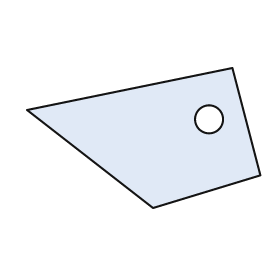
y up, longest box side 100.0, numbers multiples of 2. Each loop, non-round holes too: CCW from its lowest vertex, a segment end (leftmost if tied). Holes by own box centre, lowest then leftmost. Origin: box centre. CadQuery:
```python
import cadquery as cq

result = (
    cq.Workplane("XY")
    .moveTo(4.0, -30.0)
    .lineTo(50.0, -16.0)
    .lineTo(38.0, 30.0)
    .lineTo(-50.0, 12.0)
    .close()
    .moveTo(28.0, 8.0)
    .circle(6.0)
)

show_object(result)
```